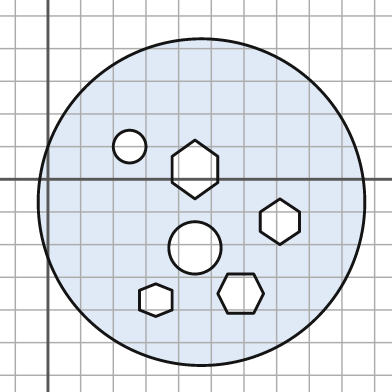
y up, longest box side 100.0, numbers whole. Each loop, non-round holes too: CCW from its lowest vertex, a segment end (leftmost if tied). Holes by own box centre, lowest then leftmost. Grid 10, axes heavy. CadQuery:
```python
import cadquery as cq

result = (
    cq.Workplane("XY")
    .moveTo(47.0, -7.0)
    .circle(50.0)
    .moveTo(33.0, -42.0)
    .lineTo(38.0, -40.0)
    .lineTo(38.0, -34.0)
    .lineTo(33.0, -32.0)
    .lineTo(28.0, -34.0)
    .lineTo(28.0, -40.0)
    .close()
    .moveTo(55.0, -41.0)
    .lineTo(63.0, -41.0)
    .lineTo(66.0, -35.0)
    .lineTo(63.0, -29.0)
    .lineTo(55.0, -29.0)
    .lineTo(52.0, -35.0)
    .close()
    .moveTo(45.0, -21.0)
    .circle(8.0)
    .moveTo(71.0, -20.0)
    .lineTo(77.0, -16.0)
    .lineTo(77.0, -10.0)
    .lineTo(71.0, -6.0)
    .lineTo(65.0, -10.0)
    .lineTo(65.0, -16.0)
    .close()
    .moveTo(45.0, -6.0)
    .lineTo(52.0, -1.0)
    .lineTo(52.0, 7.0)
    .lineTo(45.0, 12.0)
    .lineTo(38.0, 7.0)
    .lineTo(38.0, -1.0)
    .close()
    .moveTo(25.0, 10.0)
    .circle(5.0)
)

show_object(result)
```